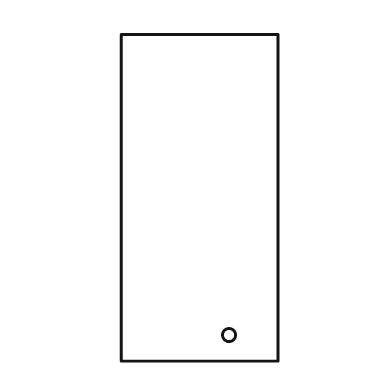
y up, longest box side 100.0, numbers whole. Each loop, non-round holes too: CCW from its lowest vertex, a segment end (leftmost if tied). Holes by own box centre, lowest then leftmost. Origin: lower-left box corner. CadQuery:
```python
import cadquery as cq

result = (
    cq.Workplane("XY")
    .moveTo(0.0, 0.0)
    .lineTo(48.0, 0.0)
    .lineTo(48.0, 100.0)
    .lineTo(0.0, 100.0)
    .close()
    .moveTo(33.0, 8.0)
    .circle(2.0)
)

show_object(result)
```